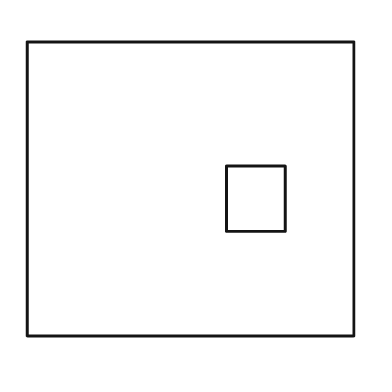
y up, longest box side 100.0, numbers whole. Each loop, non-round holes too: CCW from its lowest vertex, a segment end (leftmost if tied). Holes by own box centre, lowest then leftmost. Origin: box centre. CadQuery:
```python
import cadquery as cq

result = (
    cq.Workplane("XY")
    .moveTo(-50.0, -45.0)
    .lineTo(50.0, -45.0)
    .lineTo(50.0, 45.0)
    .lineTo(-50.0, 45.0)
    .close()
    .moveTo(11.0, -13.0)
    .lineTo(29.0, -13.0)
    .lineTo(29.0, 7.0)
    .lineTo(11.0, 7.0)
    .close()
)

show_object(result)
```